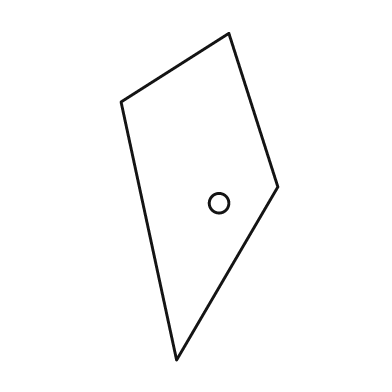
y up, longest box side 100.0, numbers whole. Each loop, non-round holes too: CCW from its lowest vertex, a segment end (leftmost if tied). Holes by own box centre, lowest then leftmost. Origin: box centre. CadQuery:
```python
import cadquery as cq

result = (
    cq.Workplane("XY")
    .moveTo(-7.0, -50.0)
    .lineTo(24.0, 3.0)
    .lineTo(9.0, 50.0)
    .lineTo(-24.0, 29.0)
    .close()
    .moveTo(6.0, -2.0)
    .circle(3.0)
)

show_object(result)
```